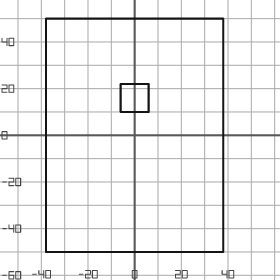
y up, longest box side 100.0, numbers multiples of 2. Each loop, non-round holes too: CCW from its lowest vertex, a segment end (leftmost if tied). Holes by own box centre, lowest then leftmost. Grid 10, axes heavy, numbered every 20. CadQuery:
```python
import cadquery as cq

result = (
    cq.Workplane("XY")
    .moveTo(-38.0, -50.0)
    .lineTo(38.0, -50.0)
    .lineTo(38.0, 50.0)
    .lineTo(-38.0, 50.0)
    .close()
    .moveTo(-6.0, 10.0)
    .lineTo(6.0, 10.0)
    .lineTo(6.0, 22.0)
    .lineTo(-6.0, 22.0)
    .close()
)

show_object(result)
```